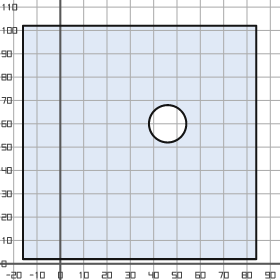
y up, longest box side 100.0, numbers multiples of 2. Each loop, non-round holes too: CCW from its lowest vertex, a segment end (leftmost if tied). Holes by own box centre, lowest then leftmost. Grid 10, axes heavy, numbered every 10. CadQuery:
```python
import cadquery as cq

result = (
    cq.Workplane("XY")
    .moveTo(-16.0, 2.0)
    .lineTo(84.0, 2.0)
    .lineTo(84.0, 102.0)
    .lineTo(-16.0, 102.0)
    .close()
    .moveTo(46.0, 60.0)
    .circle(8.0)
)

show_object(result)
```